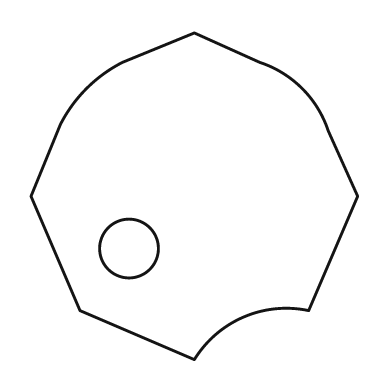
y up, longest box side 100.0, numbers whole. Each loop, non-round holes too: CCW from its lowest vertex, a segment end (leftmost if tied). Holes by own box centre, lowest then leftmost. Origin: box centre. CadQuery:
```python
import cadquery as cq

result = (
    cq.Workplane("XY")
    .moveTo(0.0, -50.0)
    .threePointArc((15.0, -37.0), (35.0, -35.0))
    .lineTo(50.0, 0.0)
    .lineTo(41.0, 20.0)
    .threePointArc((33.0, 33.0), (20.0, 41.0))
    .lineTo(0.0, 50.0)
    .lineTo(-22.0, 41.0)
    .threePointArc((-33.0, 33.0), (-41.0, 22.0))
    .lineTo(-50.0, 0.0)
    .lineTo(-35.0, -35.0)
    .close()
    .moveTo(-20.0, -16.0)
    .circle(9.0)
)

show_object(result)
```